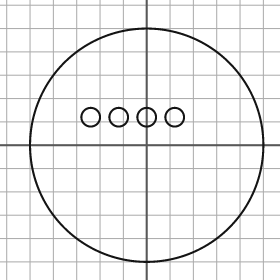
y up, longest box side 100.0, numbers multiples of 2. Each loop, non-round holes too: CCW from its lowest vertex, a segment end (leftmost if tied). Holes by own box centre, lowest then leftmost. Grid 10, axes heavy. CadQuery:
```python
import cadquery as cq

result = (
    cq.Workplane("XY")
    .moveTo(0.0, 0.0)
    .circle(50.0)
    .moveTo(-24.0, 12.0)
    .circle(4.0)
    .moveTo(-12.0, 12.0)
    .circle(4.0)
    .moveTo(0.0, 12.0)
    .circle(4.0)
    .moveTo(12.0, 12.0)
    .circle(4.0)
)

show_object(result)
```